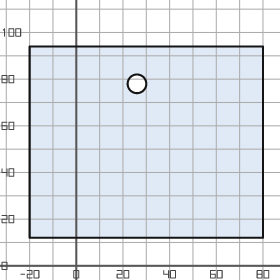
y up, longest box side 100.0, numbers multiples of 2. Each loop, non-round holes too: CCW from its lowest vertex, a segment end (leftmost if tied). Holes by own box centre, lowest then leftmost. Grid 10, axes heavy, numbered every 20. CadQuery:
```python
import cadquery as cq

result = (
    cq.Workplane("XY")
    .moveTo(-20.0, 12.0)
    .lineTo(80.0, 12.0)
    .lineTo(80.0, 94.0)
    .lineTo(-20.0, 94.0)
    .close()
    .moveTo(26.0, 78.0)
    .circle(4.0)
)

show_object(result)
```